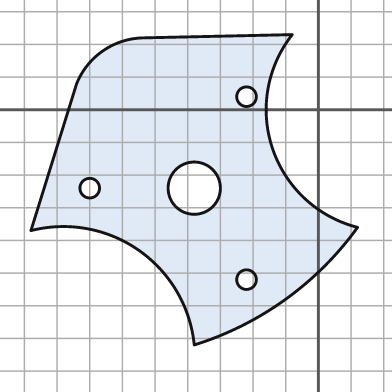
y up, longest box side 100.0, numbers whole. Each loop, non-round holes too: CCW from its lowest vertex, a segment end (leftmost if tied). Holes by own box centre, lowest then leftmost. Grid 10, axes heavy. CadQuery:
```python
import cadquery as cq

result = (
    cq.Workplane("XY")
    .moveTo(-38.0, -72.0)
    .threePointArc((-10.0, -58.0), (12.0, -36.0))
    .threePointArc((-14.0, -12.0), (-8.0, 23.0))
    .lineTo(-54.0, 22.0)
    .threePointArc((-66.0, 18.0), (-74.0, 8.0))
    .lineTo(-88.0, -37.0)
    .threePointArc((-55.0, -43.0), (-38.0, -72.0))
    .close()
    .moveTo(-22.0, -52.0)
    .circle(3.0)
    .moveTo(-70.0, -24.0)
    .circle(3.0)
    .moveTo(-38.0, -24.0)
    .circle(8.0)
    .moveTo(-22.0, 4.0)
    .circle(3.0)
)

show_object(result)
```